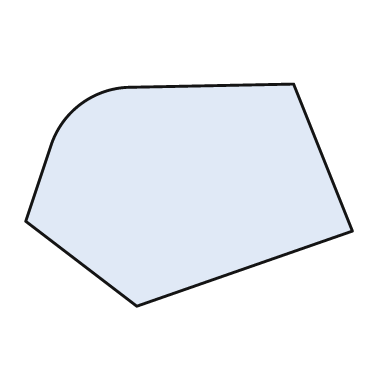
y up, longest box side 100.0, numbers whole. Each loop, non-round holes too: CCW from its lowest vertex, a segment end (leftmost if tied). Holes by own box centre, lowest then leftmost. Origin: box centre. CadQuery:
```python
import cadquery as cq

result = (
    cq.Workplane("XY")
    .moveTo(-16.0, -34.0)
    .lineTo(50.0, -11.0)
    .lineTo(32.0, 34.0)
    .lineTo(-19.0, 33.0)
    .threePointArc((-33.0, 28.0), (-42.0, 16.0))
    .lineTo(-50.0, -8.0)
    .close()
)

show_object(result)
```